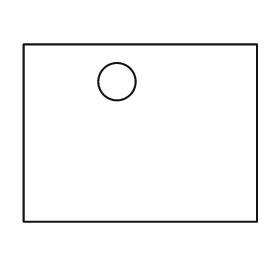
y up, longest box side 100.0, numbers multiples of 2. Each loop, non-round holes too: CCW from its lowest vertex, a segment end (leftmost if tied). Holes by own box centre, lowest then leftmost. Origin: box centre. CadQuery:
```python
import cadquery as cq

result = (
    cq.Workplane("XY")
    .moveTo(-50.0, -38.0)
    .lineTo(50.0, -38.0)
    .lineTo(50.0, 38.0)
    .lineTo(-50.0, 38.0)
    .close()
    .moveTo(-10.0, 22.0)
    .circle(8.0)
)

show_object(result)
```